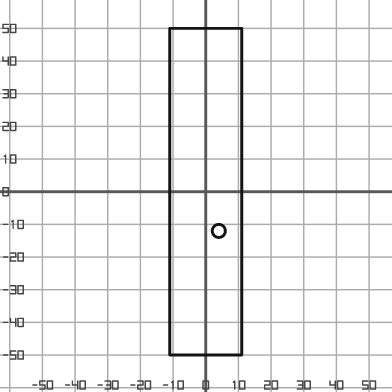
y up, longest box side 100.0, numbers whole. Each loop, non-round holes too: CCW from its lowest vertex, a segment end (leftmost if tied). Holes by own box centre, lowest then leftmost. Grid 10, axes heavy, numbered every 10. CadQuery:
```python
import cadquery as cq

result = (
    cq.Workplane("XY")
    .moveTo(-11.0, -50.0)
    .lineTo(11.0, -50.0)
    .lineTo(11.0, 50.0)
    .lineTo(-11.0, 50.0)
    .close()
    .moveTo(4.0, -12.0)
    .circle(2.0)
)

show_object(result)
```